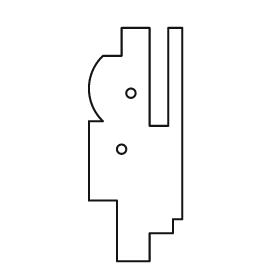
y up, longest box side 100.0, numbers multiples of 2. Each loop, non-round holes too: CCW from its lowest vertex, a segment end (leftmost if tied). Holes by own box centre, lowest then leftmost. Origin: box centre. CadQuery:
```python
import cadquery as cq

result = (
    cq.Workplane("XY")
    .moveTo(-8.0, -50.0)
    .lineTo(6.0, -50.0)
    .lineTo(6.0, -38.0)
    .lineTo(16.0, -38.0)
    .lineTo(16.0, -32.0)
    .lineTo(20.0, -32.0)
    .lineTo(20.0, 50.0)
    .lineTo(14.0, 50.0)
    .lineTo(14.0, 8.0)
    .lineTo(6.0, 8.0)
    .lineTo(6.0, 50.0)
    .lineTo(-6.0, 50.0)
    .lineTo(-6.0, 38.0)
    .lineTo(-14.0, 38.0)
    .threePointArc((-20.0, 24.0), (-14.0, 10.0))
    .lineTo(-20.0, 10.0)
    .lineTo(-20.0, -24.0)
    .lineTo(-8.0, -24.0)
    .close()
    .moveTo(-6.0, -2.0)
    .circle(2.0)
    .moveTo(-2.0, 22.0)
    .circle(2.0)
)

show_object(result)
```